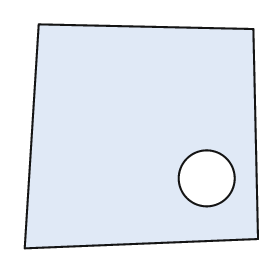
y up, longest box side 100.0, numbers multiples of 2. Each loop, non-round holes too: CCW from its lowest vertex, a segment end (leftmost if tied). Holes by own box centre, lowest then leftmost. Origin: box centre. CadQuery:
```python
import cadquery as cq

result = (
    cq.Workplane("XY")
    .moveTo(-50.0, -48.0)
    .lineTo(50.0, -44.0)
    .lineTo(48.0, 46.0)
    .lineTo(-44.0, 48.0)
    .close()
    .moveTo(28.0, -18.0)
    .circle(12.0)
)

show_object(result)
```